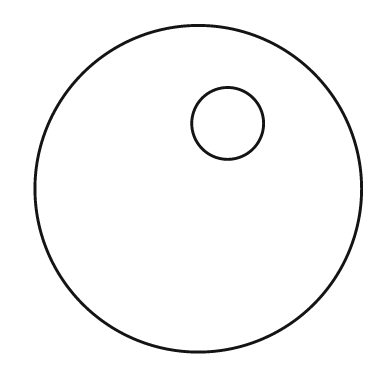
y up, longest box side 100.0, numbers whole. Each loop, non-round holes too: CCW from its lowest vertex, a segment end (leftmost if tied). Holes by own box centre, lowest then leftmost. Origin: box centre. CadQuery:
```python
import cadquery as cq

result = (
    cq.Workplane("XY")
    .moveTo(0.0, 0.0)
    .circle(50.0)
    .moveTo(9.0, 20.0)
    .circle(11.0)
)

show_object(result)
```